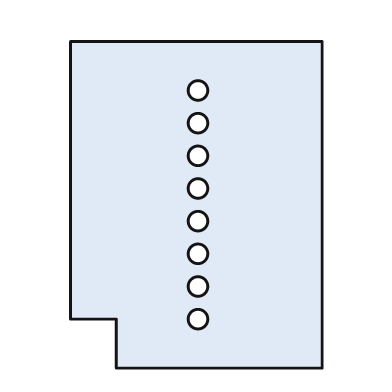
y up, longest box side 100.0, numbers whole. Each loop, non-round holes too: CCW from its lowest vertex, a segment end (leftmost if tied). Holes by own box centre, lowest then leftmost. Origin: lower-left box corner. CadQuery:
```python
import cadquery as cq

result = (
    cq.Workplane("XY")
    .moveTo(14.0, 0.0)
    .lineTo(77.0, 0.0)
    .lineTo(77.0, 100.0)
    .lineTo(0.0, 100.0)
    .lineTo(0.0, 15.0)
    .lineTo(14.0, 15.0)
    .close()
    .moveTo(39.0, 15.0)
    .circle(3.0)
    .moveTo(39.0, 25.0)
    .circle(3.0)
    .moveTo(39.0, 35.0)
    .circle(3.0)
    .moveTo(39.0, 45.0)
    .circle(3.0)
    .moveTo(39.0, 55.0)
    .circle(3.0)
    .moveTo(39.0, 65.0)
    .circle(3.0)
    .moveTo(39.0, 75.0)
    .circle(3.0)
    .moveTo(39.0, 85.0)
    .circle(3.0)
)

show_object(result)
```